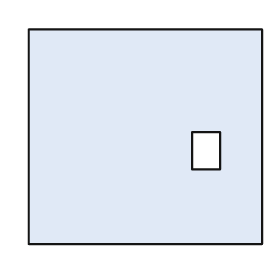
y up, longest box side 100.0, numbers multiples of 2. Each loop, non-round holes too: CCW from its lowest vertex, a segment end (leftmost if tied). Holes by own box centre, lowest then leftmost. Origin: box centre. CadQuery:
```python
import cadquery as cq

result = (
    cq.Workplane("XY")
    .moveTo(-50.0, -46.0)
    .lineTo(50.0, -46.0)
    .lineTo(50.0, 46.0)
    .lineTo(-50.0, 46.0)
    .close()
    .moveTo(20.0, -14.0)
    .lineTo(32.0, -14.0)
    .lineTo(32.0, 2.0)
    .lineTo(20.0, 2.0)
    .close()
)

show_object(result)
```